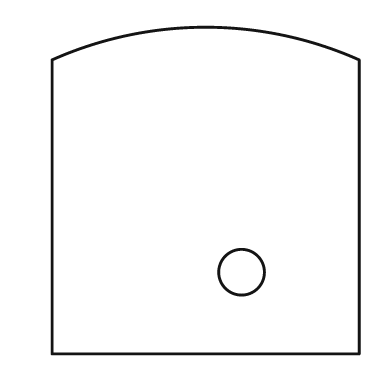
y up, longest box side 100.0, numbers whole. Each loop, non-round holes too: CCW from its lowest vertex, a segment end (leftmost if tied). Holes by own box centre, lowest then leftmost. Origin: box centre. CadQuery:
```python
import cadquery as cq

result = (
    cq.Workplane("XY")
    .moveTo(-47.0, -50.0)
    .lineTo(47.0, -50.0)
    .lineTo(47.0, 40.0)
    .threePointArc((0.0, 50.0), (-47.0, 40.0))
    .close()
    .moveTo(11.0, -25.0)
    .circle(7.0)
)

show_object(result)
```